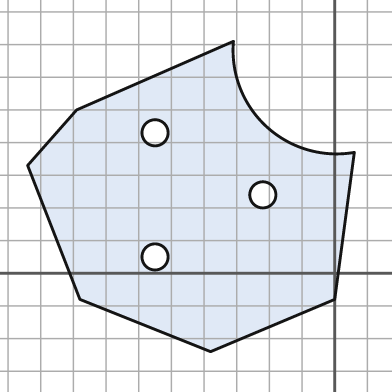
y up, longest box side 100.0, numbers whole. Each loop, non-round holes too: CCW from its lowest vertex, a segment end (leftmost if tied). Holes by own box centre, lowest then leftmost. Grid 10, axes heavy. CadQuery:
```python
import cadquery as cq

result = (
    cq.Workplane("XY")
    .moveTo(-38.0, -24.0)
    .lineTo(0.0, -8.0)
    .lineTo(6.0, 37.0)
    .threePointArc((-21.0, 45.0), (-31.0, 71.0))
    .lineTo(-79.0, 50.0)
    .lineTo(-94.0, 33.0)
    .lineTo(-78.0, -8.0)
    .close()
    .moveTo(-55.0, 5.0)
    .circle(4.0)
    .moveTo(-22.0, 24.0)
    .circle(4.0)
    .moveTo(-55.0, 43.0)
    .circle(4.0)
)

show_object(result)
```